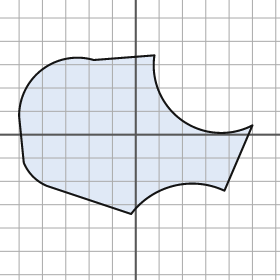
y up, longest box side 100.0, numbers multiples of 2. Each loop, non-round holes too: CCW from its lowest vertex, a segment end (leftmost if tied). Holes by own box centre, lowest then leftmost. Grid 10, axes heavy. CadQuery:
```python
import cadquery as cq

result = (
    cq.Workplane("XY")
    .moveTo(-2.0, -34.0)
    .threePointArc((16.0, -22.0), (38.0, -24.0))
    .lineTo(50.0, 4.0)
    .threePointArc((20.0, 6.0), (8.0, 34.0))
    .lineTo(-18.0, 32.0)
    .threePointArc((-40.0, 28.0), (-50.0, 8.0))
    .lineTo(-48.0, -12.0)
    .threePointArc((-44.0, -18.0), (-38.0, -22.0))
    .close()
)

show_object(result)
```